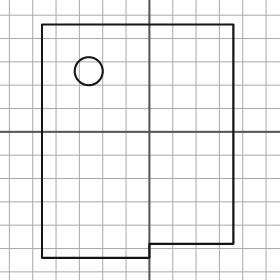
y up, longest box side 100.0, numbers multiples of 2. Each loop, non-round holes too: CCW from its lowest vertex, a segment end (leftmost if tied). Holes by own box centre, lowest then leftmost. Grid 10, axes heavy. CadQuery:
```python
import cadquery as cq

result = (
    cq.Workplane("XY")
    .moveTo(-46.0, -54.0)
    .lineTo(0.0, -54.0)
    .lineTo(0.0, -48.0)
    .lineTo(36.0, -48.0)
    .lineTo(36.0, 46.0)
    .lineTo(-46.0, 46.0)
    .close()
    .moveTo(-26.0, 26.0)
    .circle(6.0)
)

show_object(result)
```